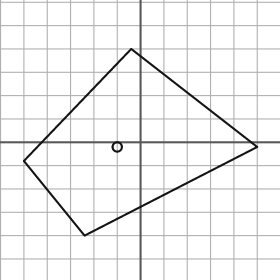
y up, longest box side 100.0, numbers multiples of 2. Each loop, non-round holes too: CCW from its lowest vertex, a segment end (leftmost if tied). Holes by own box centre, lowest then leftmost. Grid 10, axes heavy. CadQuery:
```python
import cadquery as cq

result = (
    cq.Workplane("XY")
    .moveTo(-24.0, -40.0)
    .lineTo(50.0, -2.0)
    .lineTo(-4.0, 40.0)
    .lineTo(-50.0, -8.0)
    .close()
    .moveTo(-10.0, -2.0)
    .circle(2.0)
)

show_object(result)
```